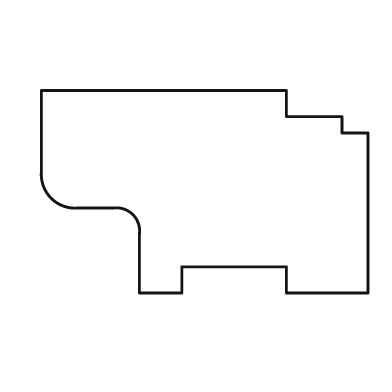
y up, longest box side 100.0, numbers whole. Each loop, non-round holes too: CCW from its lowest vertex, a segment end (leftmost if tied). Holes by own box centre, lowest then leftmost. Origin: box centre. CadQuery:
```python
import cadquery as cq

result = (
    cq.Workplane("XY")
    .moveTo(-20.0, -31.0)
    .lineTo(-7.0, -31.0)
    .lineTo(-7.0, -23.0)
    .lineTo(25.0, -23.0)
    .lineTo(25.0, -31.0)
    .lineTo(50.0, -31.0)
    .lineTo(50.0, 18.0)
    .lineTo(42.0, 18.0)
    .lineTo(42.0, 23.0)
    .lineTo(25.0, 23.0)
    .lineTo(25.0, 31.0)
    .lineTo(-50.0, 31.0)
    .lineTo(-50.0, 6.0)
    .threePointArc((-47.0, -2.0), (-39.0, -5.0))
    .lineTo(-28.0, -5.0)
    .threePointArc((-22.0, -7.0), (-20.0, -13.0))
    .close()
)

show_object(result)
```